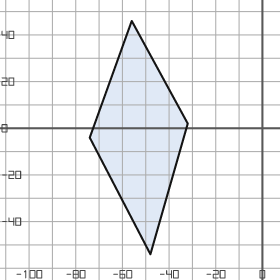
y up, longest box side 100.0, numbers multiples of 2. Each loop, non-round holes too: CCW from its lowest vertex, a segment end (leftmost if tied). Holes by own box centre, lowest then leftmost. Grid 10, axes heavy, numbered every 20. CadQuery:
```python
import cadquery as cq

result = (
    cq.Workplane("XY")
    .moveTo(-48.0, -54.0)
    .lineTo(-32.0, 2.0)
    .lineTo(-56.0, 46.0)
    .lineTo(-74.0, -4.0)
    .close()
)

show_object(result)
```